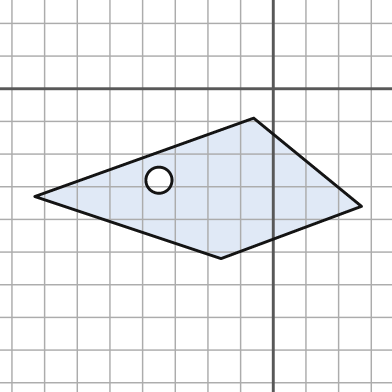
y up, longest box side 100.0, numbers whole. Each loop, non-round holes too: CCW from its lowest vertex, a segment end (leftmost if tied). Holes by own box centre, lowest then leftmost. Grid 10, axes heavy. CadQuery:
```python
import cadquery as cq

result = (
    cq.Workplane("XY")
    .moveTo(-16.0, -52.0)
    .lineTo(27.0, -36.0)
    .lineTo(-6.0, -9.0)
    .lineTo(-73.0, -33.0)
    .close()
    .moveTo(-35.0, -28.0)
    .circle(4.0)
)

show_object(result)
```